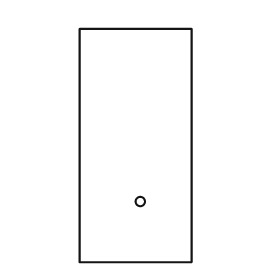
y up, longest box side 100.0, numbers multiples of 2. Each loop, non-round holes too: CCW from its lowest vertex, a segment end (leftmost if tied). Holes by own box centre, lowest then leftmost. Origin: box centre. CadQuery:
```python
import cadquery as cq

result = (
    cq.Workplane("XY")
    .moveTo(-24.0, -50.0)
    .lineTo(24.0, -50.0)
    .lineTo(24.0, 50.0)
    .lineTo(-24.0, 50.0)
    .close()
    .moveTo(2.0, -24.0)
    .circle(2.0)
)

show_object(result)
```